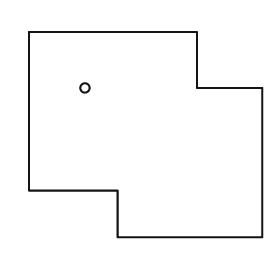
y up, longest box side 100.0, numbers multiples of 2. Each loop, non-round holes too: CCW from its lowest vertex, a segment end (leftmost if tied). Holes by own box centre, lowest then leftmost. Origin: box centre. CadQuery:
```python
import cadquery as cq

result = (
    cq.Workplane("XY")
    .moveTo(-12.0, -44.0)
    .lineTo(50.0, -44.0)
    .lineTo(50.0, 20.0)
    .lineTo(22.0, 20.0)
    .lineTo(22.0, 44.0)
    .lineTo(-50.0, 44.0)
    .lineTo(-50.0, -24.0)
    .lineTo(-12.0, -24.0)
    .close()
    .moveTo(-26.0, 20.0)
    .circle(2.0)
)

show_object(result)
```